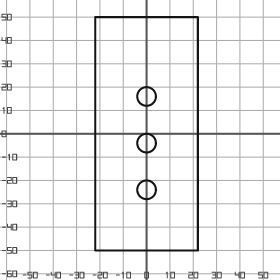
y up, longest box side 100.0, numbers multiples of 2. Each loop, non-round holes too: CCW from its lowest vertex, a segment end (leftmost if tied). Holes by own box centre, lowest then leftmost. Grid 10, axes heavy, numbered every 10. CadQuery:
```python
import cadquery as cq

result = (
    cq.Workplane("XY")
    .moveTo(-22.0, -50.0)
    .lineTo(22.0, -50.0)
    .lineTo(22.0, 50.0)
    .lineTo(-22.0, 50.0)
    .close()
    .moveTo(0.0, -24.0)
    .circle(4.0)
    .moveTo(0.0, -4.0)
    .circle(4.0)
    .moveTo(0.0, 16.0)
    .circle(4.0)
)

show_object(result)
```